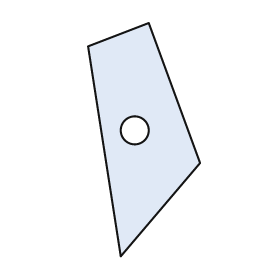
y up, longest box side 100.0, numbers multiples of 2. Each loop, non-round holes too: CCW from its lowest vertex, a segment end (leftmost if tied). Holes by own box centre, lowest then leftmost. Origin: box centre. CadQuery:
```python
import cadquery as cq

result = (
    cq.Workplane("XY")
    .moveTo(-10.0, -50.0)
    .lineTo(24.0, -10.0)
    .lineTo(2.0, 50.0)
    .lineTo(-24.0, 40.0)
    .close()
    .moveTo(-4.0, 4.0)
    .circle(6.0)
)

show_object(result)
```